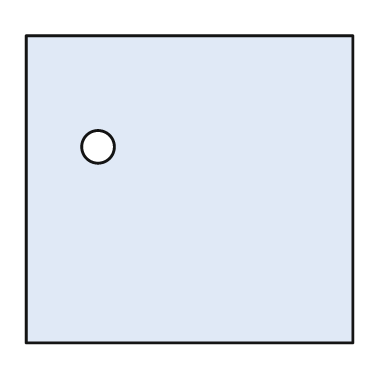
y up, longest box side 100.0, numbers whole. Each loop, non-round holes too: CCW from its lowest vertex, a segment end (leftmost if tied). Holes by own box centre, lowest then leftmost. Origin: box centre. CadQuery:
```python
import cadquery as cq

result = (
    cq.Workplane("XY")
    .moveTo(-50.0, -47.0)
    .lineTo(50.0, -47.0)
    .lineTo(50.0, 47.0)
    .lineTo(-50.0, 47.0)
    .close()
    .moveTo(-28.0, 13.0)
    .circle(5.0)
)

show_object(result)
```